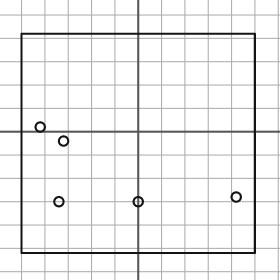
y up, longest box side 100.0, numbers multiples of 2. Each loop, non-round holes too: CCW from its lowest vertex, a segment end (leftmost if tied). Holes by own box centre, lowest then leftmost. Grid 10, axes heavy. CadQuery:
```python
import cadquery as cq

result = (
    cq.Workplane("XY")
    .moveTo(-50.0, -52.0)
    .lineTo(50.0, -52.0)
    .lineTo(50.0, 42.0)
    .lineTo(-50.0, 42.0)
    .close()
    .moveTo(-34.0, -30.0)
    .circle(2.0)
    .moveTo(0.0, -30.0)
    .circle(2.0)
    .moveTo(42.0, -28.0)
    .circle(2.0)
    .moveTo(-32.0, -4.0)
    .circle(2.0)
    .moveTo(-42.0, 2.0)
    .circle(2.0)
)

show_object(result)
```